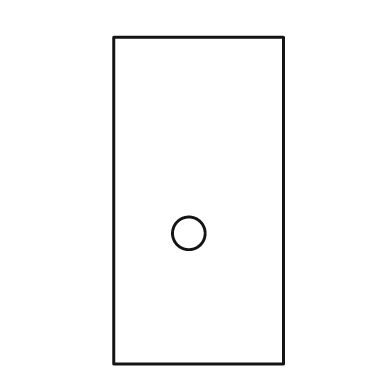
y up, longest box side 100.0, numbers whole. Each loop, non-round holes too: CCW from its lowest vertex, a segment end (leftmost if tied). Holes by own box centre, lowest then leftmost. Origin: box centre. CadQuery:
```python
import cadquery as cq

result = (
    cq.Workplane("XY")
    .moveTo(-26.0, -50.0)
    .lineTo(26.0, -50.0)
    .lineTo(26.0, 50.0)
    .lineTo(-26.0, 50.0)
    .close()
    .moveTo(-3.0, -10.0)
    .circle(5.0)
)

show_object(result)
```